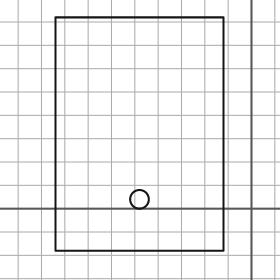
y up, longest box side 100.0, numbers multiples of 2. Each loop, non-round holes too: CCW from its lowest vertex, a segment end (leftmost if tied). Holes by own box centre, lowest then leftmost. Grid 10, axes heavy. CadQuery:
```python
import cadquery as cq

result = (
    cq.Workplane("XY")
    .moveTo(-84.0, -18.0)
    .lineTo(-12.0, -18.0)
    .lineTo(-12.0, 82.0)
    .lineTo(-84.0, 82.0)
    .close()
    .moveTo(-48.0, 4.0)
    .circle(4.0)
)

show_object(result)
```